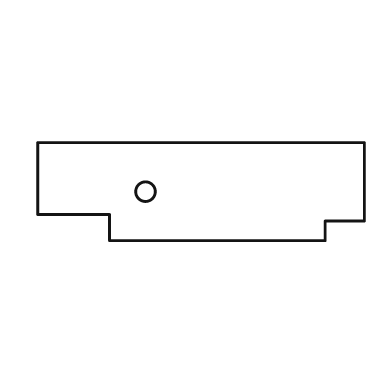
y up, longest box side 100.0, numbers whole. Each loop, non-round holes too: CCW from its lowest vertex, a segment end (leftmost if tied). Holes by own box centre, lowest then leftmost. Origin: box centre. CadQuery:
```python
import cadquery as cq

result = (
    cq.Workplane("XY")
    .moveTo(-28.0, -15.0)
    .lineTo(38.0, -15.0)
    .lineTo(38.0, -9.0)
    .lineTo(50.0, -9.0)
    .lineTo(50.0, 15.0)
    .lineTo(-50.0, 15.0)
    .lineTo(-50.0, -7.0)
    .lineTo(-28.0, -7.0)
    .close()
    .moveTo(-17.0, 0.0)
    .circle(3.0)
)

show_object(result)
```